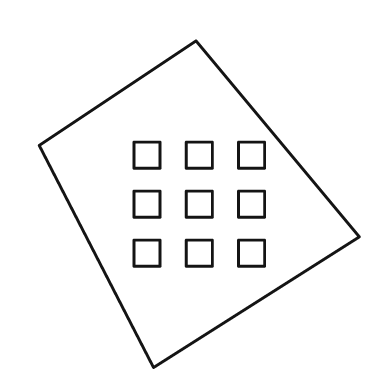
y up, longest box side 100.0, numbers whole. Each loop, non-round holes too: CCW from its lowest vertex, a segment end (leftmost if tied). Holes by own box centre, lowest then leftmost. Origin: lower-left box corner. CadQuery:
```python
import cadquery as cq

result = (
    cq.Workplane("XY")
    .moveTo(35.0, 0.0)
    .lineTo(98.0, 40.0)
    .lineTo(48.0, 100.0)
    .lineTo(0.0, 68.0)
    .close()
    .moveTo(29.0, 31.0)
    .lineTo(37.0, 31.0)
    .lineTo(37.0, 39.0)
    .lineTo(29.0, 39.0)
    .close()
    .moveTo(45.0, 31.0)
    .lineTo(53.0, 31.0)
    .lineTo(53.0, 39.0)
    .lineTo(45.0, 39.0)
    .close()
    .moveTo(61.0, 31.0)
    .lineTo(69.0, 31.0)
    .lineTo(69.0, 39.0)
    .lineTo(61.0, 39.0)
    .close()
    .moveTo(29.0, 46.0)
    .lineTo(37.0, 46.0)
    .lineTo(37.0, 54.0)
    .lineTo(29.0, 54.0)
    .close()
    .moveTo(45.0, 46.0)
    .lineTo(53.0, 46.0)
    .lineTo(53.0, 54.0)
    .lineTo(45.0, 54.0)
    .close()
    .moveTo(61.0, 46.0)
    .lineTo(69.0, 46.0)
    .lineTo(69.0, 54.0)
    .lineTo(61.0, 54.0)
    .close()
    .moveTo(29.0, 61.0)
    .lineTo(37.0, 61.0)
    .lineTo(37.0, 69.0)
    .lineTo(29.0, 69.0)
    .close()
    .moveTo(45.0, 61.0)
    .lineTo(53.0, 61.0)
    .lineTo(53.0, 69.0)
    .lineTo(45.0, 69.0)
    .close()
    .moveTo(61.0, 61.0)
    .lineTo(69.0, 61.0)
    .lineTo(69.0, 69.0)
    .lineTo(61.0, 69.0)
    .close()
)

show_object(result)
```